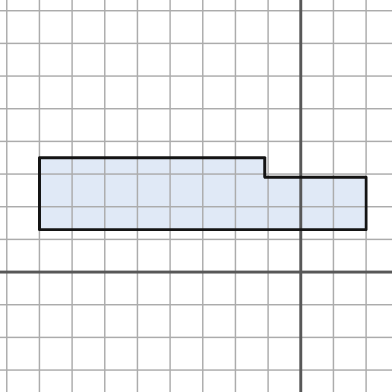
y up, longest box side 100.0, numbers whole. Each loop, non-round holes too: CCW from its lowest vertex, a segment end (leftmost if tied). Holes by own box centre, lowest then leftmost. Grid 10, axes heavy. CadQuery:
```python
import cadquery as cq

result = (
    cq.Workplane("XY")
    .moveTo(-80.0, 13.0)
    .lineTo(20.0, 13.0)
    .lineTo(20.0, 29.0)
    .lineTo(-11.0, 29.0)
    .lineTo(-11.0, 35.0)
    .lineTo(-80.0, 35.0)
    .close()
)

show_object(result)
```